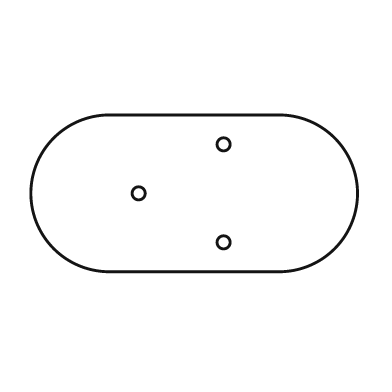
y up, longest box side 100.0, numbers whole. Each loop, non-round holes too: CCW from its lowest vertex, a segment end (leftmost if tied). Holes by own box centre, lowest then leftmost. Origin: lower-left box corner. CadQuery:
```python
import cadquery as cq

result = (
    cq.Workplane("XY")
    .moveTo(24.0, 0.0)
    .lineTo(76.0, 0.0)
    .threePointArc((100.0, 24.0), (76.0, 48.0))
    .lineTo(24.0, 48.0)
    .threePointArc((0.0, 24.0), (24.0, 0.0))
    .close()
    .moveTo(59.0, 9.0)
    .circle(2.0)
    .moveTo(33.0, 24.0)
    .circle(2.0)
    .moveTo(59.0, 39.0)
    .circle(2.0)
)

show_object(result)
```